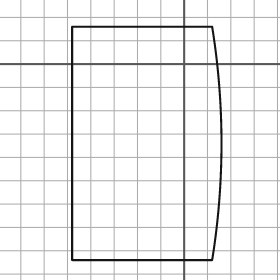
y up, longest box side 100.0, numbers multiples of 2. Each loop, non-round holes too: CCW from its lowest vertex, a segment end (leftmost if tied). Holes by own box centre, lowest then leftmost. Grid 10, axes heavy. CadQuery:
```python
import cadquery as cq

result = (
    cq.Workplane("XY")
    .moveTo(-48.0, -84.0)
    .lineTo(12.0, -84.0)
    .threePointArc((16.0, -34.0), (12.0, 16.0))
    .lineTo(-48.0, 16.0)
    .close()
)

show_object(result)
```